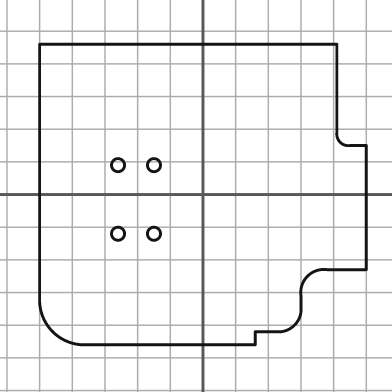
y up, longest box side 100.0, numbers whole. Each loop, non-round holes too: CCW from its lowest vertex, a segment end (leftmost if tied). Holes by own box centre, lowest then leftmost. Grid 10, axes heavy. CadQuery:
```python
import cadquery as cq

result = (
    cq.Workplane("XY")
    .moveTo(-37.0, -46.0)
    .lineTo(16.0, -46.0)
    .lineTo(16.0, -42.0)
    .lineTo(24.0, -42.0)
    .threePointArc((28.0, -40.0), (30.0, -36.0))
    .lineTo(30.0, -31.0)
    .threePointArc((32.0, -25.0), (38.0, -23.0))
    .lineTo(50.0, -23.0)
    .lineTo(50.0, 15.0)
    .lineTo(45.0, 15.0)
    .threePointArc((42.0, 16.0), (41.0, 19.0))
    .lineTo(41.0, 46.0)
    .lineTo(-50.0, 46.0)
    .lineTo(-50.0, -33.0)
    .threePointArc((-46.0, -42.0), (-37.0, -46.0))
    .close()
    .moveTo(-26.0, -12.0)
    .circle(2.0)
    .moveTo(-15.0, -12.0)
    .circle(2.0)
    .moveTo(-26.0, 9.0)
    .circle(2.0)
    .moveTo(-15.0, 9.0)
    .circle(2.0)
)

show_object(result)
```